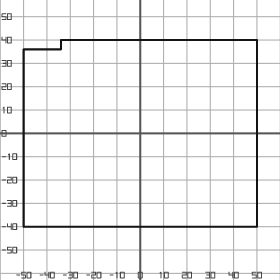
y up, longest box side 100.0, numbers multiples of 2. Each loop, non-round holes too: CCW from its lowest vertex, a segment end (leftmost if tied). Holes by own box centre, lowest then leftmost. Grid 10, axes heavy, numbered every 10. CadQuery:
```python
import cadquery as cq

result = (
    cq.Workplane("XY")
    .moveTo(-50.0, -40.0)
    .lineTo(50.0, -40.0)
    .lineTo(50.0, 40.0)
    .lineTo(-34.0, 40.0)
    .lineTo(-34.0, 36.0)
    .lineTo(-50.0, 36.0)
    .close()
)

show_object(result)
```